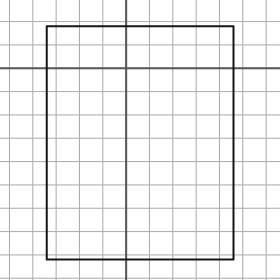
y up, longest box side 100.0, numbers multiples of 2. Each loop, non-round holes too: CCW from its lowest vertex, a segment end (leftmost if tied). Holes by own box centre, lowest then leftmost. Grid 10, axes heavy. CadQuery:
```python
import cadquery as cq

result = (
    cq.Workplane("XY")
    .moveTo(-34.0, -82.0)
    .lineTo(46.0, -82.0)
    .lineTo(46.0, 18.0)
    .lineTo(-34.0, 18.0)
    .close()
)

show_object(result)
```